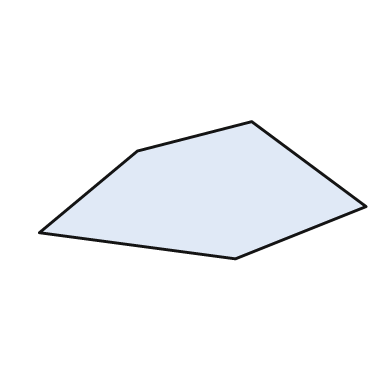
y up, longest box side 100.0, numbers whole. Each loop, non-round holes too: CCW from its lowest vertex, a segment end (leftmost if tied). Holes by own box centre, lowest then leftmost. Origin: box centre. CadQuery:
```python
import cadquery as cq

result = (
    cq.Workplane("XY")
    .moveTo(10.0, -21.0)
    .lineTo(50.0, -5.0)
    .lineTo(15.0, 21.0)
    .lineTo(-20.0, 12.0)
    .lineTo(-50.0, -13.0)
    .close()
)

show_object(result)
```